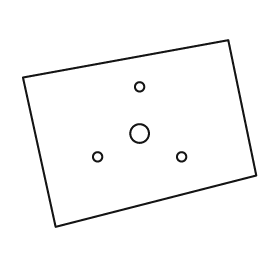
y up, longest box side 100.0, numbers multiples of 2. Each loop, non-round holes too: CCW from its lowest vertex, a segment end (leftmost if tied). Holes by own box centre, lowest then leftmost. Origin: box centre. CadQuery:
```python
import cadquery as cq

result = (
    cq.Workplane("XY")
    .moveTo(-36.0, -40.0)
    .lineTo(50.0, -18.0)
    .lineTo(38.0, 40.0)
    .lineTo(-50.0, 24.0)
    .close()
    .moveTo(-18.0, -10.0)
    .circle(2.0)
    .moveTo(18.0, -10.0)
    .circle(2.0)
    .moveTo(0.0, 0.0)
    .circle(4.0)
    .moveTo(0.0, 20.0)
    .circle(2.0)
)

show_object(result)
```